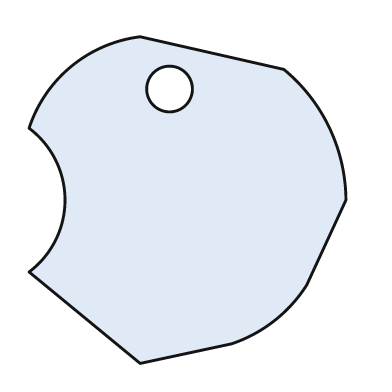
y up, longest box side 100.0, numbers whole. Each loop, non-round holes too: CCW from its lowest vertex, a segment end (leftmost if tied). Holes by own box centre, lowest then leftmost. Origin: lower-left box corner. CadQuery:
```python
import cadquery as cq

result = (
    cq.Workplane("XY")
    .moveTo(34.0, 0.0)
    .lineTo(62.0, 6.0)
    .threePointArc((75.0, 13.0), (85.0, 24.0))
    .lineTo(97.0, 50.0)
    .threePointArc((92.0, 72.0), (78.0, 90.0))
    .lineTo(34.0, 100.0)
    .threePointArc((13.0, 91.0), (0.0, 72.0))
    .threePointArc((11.0, 50.0), (0.0, 28.0))
    .close()
    .moveTo(43.0, 84.0)
    .circle(7.0)
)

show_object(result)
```